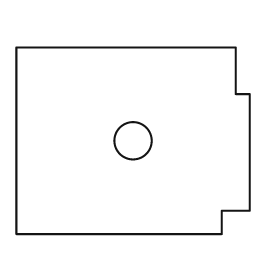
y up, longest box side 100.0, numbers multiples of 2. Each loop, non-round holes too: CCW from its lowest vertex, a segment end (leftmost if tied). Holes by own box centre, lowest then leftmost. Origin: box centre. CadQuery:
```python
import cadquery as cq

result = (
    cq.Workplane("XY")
    .moveTo(-50.0, -40.0)
    .lineTo(38.0, -40.0)
    .lineTo(38.0, -30.0)
    .lineTo(50.0, -30.0)
    .lineTo(50.0, 20.0)
    .lineTo(44.0, 20.0)
    .lineTo(44.0, 40.0)
    .lineTo(-50.0, 40.0)
    .close()
    .moveTo(0.0, 0.0)
    .circle(8.0)
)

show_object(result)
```